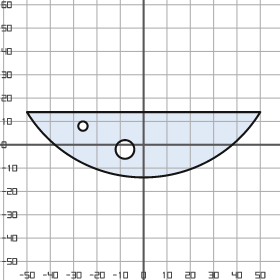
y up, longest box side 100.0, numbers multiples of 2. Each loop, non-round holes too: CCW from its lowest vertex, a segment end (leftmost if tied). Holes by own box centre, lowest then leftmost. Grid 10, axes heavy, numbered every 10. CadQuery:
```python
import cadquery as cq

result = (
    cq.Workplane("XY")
    .moveTo(-50.0, 14.0)
    .threePointArc((0.0, -14.0), (50.0, 14.0))
    .close()
    .moveTo(-8.0, -2.0)
    .circle(4.0)
    .moveTo(-26.0, 8.0)
    .circle(2.0)
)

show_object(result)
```